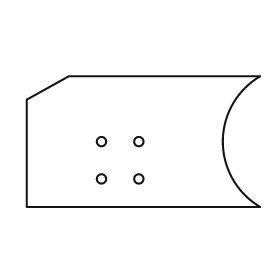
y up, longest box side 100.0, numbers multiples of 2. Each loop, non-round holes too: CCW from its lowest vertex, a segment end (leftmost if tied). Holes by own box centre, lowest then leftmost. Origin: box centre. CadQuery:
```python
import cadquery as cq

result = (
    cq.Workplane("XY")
    .moveTo(-50.0, -28.0)
    .lineTo(50.0, -28.0)
    .threePointArc((34.0, 0.0), (50.0, 28.0))
    .lineTo(-32.0, 28.0)
    .lineTo(-50.0, 18.0)
    .close()
    .moveTo(-18.0, -16.0)
    .circle(2.0)
    .moveTo(-2.0, -16.0)
    .circle(2.0)
    .moveTo(-18.0, 0.0)
    .circle(2.0)
    .moveTo(-2.0, 0.0)
    .circle(2.0)
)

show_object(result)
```